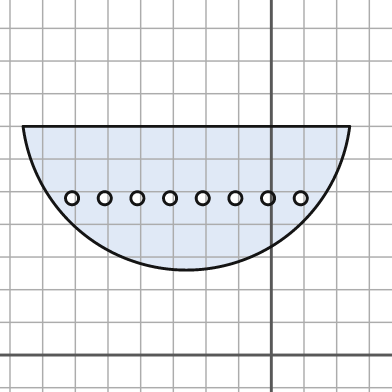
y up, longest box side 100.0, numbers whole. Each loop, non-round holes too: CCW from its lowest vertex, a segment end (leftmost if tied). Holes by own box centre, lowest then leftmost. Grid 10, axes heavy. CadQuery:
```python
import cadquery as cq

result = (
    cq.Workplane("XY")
    .moveTo(-76.0, 70.0)
    .threePointArc((-26.0, 26.0), (24.0, 70.0))
    .close()
    .moveTo(-61.0, 48.0)
    .circle(2.0)
    .moveTo(-51.0, 48.0)
    .circle(2.0)
    .moveTo(-41.0, 48.0)
    .circle(2.0)
    .moveTo(-31.0, 48.0)
    .circle(2.0)
    .moveTo(-21.0, 48.0)
    .circle(2.0)
    .moveTo(-11.0, 48.0)
    .circle(2.0)
    .moveTo(-1.0, 48.0)
    .circle(2.0)
    .moveTo(9.0, 48.0)
    .circle(2.0)
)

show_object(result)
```